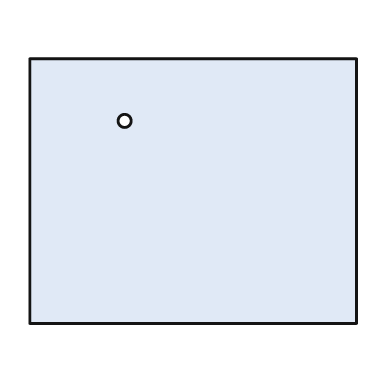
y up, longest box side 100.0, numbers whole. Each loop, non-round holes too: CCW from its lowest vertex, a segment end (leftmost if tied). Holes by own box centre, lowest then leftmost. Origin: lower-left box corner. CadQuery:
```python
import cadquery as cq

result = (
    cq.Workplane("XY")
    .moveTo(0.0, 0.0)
    .lineTo(100.0, 0.0)
    .lineTo(100.0, 81.0)
    .lineTo(0.0, 81.0)
    .close()
    .moveTo(29.0, 62.0)
    .circle(2.0)
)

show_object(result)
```